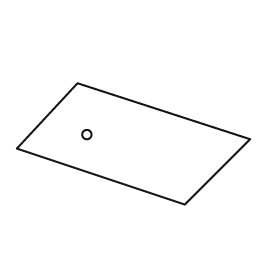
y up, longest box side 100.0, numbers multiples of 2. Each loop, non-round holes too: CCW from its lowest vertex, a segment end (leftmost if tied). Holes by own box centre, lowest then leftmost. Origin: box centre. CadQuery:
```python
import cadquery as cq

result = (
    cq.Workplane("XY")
    .moveTo(22.0, -26.0)
    .lineTo(50.0, 2.0)
    .lineTo(-24.0, 26.0)
    .lineTo(-50.0, -2.0)
    .close()
    .moveTo(-20.0, 4.0)
    .circle(2.0)
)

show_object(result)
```